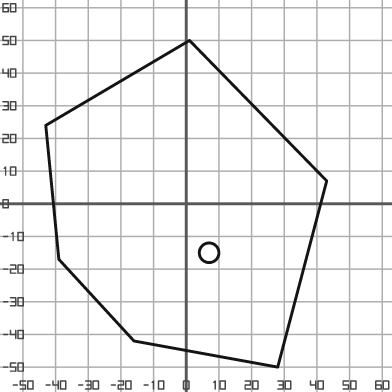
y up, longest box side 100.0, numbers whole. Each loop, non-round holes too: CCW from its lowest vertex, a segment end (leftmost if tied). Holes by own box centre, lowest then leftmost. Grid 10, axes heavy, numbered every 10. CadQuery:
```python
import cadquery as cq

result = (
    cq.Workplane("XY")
    .moveTo(28.0, -50.0)
    .lineTo(43.0, 7.0)
    .lineTo(1.0, 50.0)
    .lineTo(-43.0, 24.0)
    .lineTo(-39.0, -17.0)
    .lineTo(-16.0, -42.0)
    .close()
    .moveTo(7.0, -15.0)
    .circle(3.0)
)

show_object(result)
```